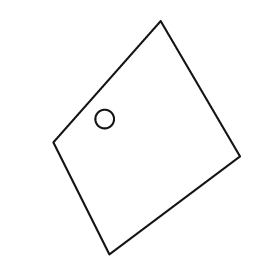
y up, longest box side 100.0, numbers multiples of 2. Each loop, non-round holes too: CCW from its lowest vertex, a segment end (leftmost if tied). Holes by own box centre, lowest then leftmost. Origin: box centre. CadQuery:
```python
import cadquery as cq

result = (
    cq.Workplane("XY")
    .moveTo(-16.0, -50.0)
    .lineTo(40.0, -8.0)
    .lineTo(6.0, 50.0)
    .lineTo(-40.0, -2.0)
    .close()
    .moveTo(-18.0, 8.0)
    .circle(4.0)
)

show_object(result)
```